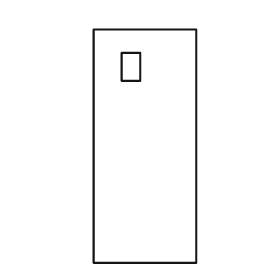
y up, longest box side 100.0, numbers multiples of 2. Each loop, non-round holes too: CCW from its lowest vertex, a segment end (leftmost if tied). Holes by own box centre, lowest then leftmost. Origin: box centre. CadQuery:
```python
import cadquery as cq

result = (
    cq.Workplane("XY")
    .moveTo(-22.0, -50.0)
    .lineTo(22.0, -50.0)
    .lineTo(22.0, 50.0)
    .lineTo(-22.0, 50.0)
    .close()
    .moveTo(-10.0, 28.0)
    .lineTo(-2.0, 28.0)
    .lineTo(-2.0, 40.0)
    .lineTo(-10.0, 40.0)
    .close()
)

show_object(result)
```